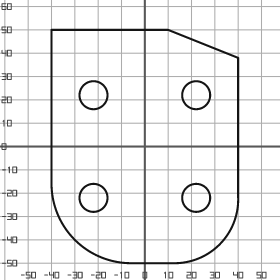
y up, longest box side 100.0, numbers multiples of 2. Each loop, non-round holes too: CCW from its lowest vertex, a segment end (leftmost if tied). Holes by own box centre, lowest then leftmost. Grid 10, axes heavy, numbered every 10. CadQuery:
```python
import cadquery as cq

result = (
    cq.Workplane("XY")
    .moveTo(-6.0, -50.0)
    .lineTo(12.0, -50.0)
    .threePointArc((32.0, -42.0), (40.0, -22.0))
    .lineTo(40.0, 38.0)
    .lineTo(10.0, 50.0)
    .lineTo(-40.0, 50.0)
    .lineTo(-40.0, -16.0)
    .threePointArc((-30.0, -40.0), (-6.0, -50.0))
    .close()
    .moveTo(-22.0, -22.0)
    .circle(6.0)
    .moveTo(22.0, -22.0)
    .circle(6.0)
    .moveTo(-22.0, 22.0)
    .circle(6.0)
    .moveTo(22.0, 22.0)
    .circle(6.0)
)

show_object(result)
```